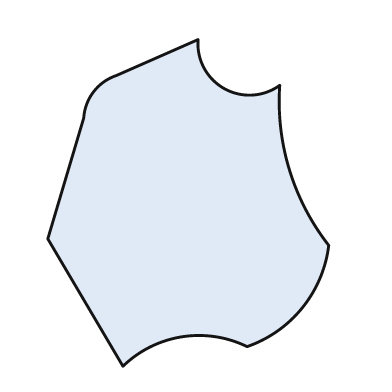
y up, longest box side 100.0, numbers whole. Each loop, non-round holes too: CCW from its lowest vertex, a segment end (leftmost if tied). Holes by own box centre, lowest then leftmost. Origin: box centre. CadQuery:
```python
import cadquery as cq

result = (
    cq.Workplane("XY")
    .moveTo(-20.0, -50.0)
    .threePointArc((-2.0, -41.0), (18.0, -44.0))
    .threePointArc((35.0, -32.0), (43.0, -13.0))
    .threePointArc((31.0, 10.0), (28.0, 36.0))
    .threePointArc((11.0, 35.0), (3.0, 50.0))
    .lineTo(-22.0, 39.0)
    .threePointArc((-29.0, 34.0), (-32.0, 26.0))
    .lineTo(-43.0, -11.0)
    .close()
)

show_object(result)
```